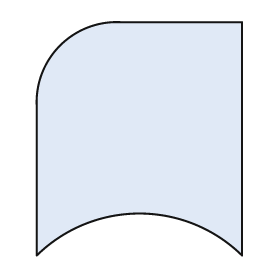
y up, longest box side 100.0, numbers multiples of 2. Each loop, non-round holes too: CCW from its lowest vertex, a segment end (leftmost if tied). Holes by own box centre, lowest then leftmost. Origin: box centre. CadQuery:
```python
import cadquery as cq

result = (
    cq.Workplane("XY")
    .moveTo(-44.0, -50.0)
    .threePointArc((0.0, -32.0), (44.0, -50.0))
    .lineTo(44.0, 50.0)
    .lineTo(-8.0, 50.0)
    .threePointArc((-34.0, 40.0), (-44.0, 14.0))
    .close()
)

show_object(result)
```